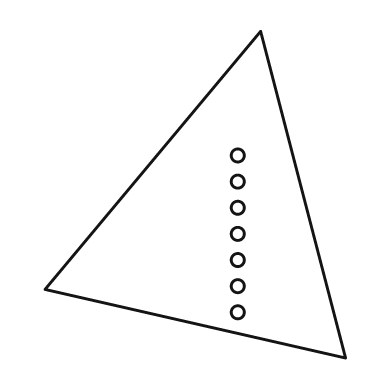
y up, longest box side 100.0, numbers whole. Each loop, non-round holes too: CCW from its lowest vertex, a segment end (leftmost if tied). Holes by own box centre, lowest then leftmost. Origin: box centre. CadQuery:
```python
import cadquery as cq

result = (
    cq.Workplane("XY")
    .moveTo(46.0, -50.0)
    .lineTo(20.0, 50.0)
    .lineTo(-46.0, -29.0)
    .close()
    .moveTo(13.0, -36.0)
    .circle(2.0)
    .moveTo(13.0, -28.0)
    .circle(2.0)
    .moveTo(13.0, -20.0)
    .circle(2.0)
    .moveTo(13.0, -12.0)
    .circle(2.0)
    .moveTo(13.0, -4.0)
    .circle(2.0)
    .moveTo(13.0, 4.0)
    .circle(2.0)
    .moveTo(13.0, 12.0)
    .circle(2.0)
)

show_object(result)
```